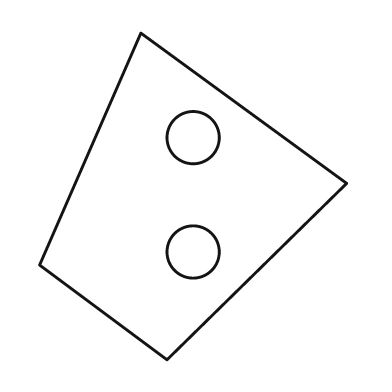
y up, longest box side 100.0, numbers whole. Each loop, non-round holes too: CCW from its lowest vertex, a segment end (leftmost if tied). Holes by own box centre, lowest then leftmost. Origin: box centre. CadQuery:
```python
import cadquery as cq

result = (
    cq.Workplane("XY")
    .moveTo(-8.0, -50.0)
    .lineTo(47.0, 4.0)
    .lineTo(-16.0, 50.0)
    .lineTo(-47.0, -21.0)
    .close()
    .moveTo(0.0, -17.0)
    .circle(8.0)
    .moveTo(0.0, 18.0)
    .circle(8.0)
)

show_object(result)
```